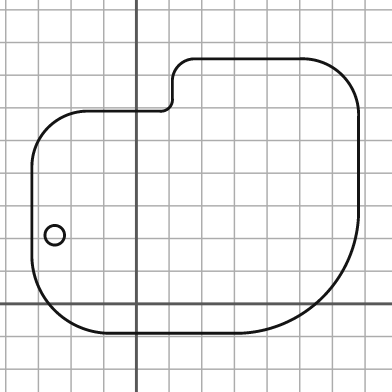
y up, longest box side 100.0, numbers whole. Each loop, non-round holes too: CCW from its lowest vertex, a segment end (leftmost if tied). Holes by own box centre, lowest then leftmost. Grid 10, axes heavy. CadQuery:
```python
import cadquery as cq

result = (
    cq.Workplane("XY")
    .moveTo(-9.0, -9.0)
    .lineTo(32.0, -9.0)
    .threePointArc((57.0, 2.0), (68.0, 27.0))
    .lineTo(68.0, 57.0)
    .threePointArc((63.0, 70.0), (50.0, 75.0))
    .lineTo(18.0, 75.0)
    .threePointArc((13.0, 73.0), (11.0, 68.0))
    .lineTo(11.0, 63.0)
    .threePointArc((10.0, 60.0), (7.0, 59.0))
    .lineTo(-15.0, 59.0)
    .threePointArc((-27.0, 54.0), (-32.0, 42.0))
    .lineTo(-32.0, 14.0)
    .threePointArc((-25.0, -2.0), (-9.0, -9.0))
    .close()
    .moveTo(-25.0, 21.0)
    .circle(3.0)
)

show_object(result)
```